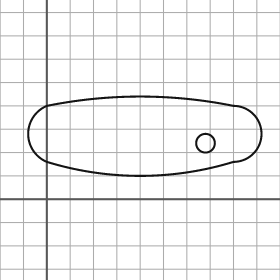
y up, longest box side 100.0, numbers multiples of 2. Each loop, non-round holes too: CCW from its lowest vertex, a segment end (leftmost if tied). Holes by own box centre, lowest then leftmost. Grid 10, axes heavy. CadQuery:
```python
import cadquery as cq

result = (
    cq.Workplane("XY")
    .moveTo(0.0, 16.0)
    .threePointArc((40.0, 10.0), (80.0, 16.0))
    .threePointArc((92.0, 28.0), (80.0, 40.0))
    .threePointArc((40.0, 44.0), (0.0, 40.0))
    .threePointArc((-8.0, 28.0), (0.0, 16.0))
    .close()
    .moveTo(68.0, 24.0)
    .circle(4.0)
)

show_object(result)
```